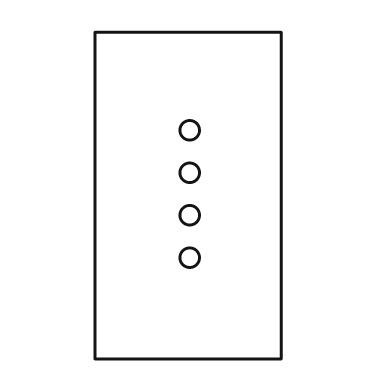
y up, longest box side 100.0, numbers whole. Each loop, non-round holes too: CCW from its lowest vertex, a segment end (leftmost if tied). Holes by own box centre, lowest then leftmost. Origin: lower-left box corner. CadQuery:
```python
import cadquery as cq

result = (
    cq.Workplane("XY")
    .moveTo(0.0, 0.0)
    .lineTo(57.0, 0.0)
    .lineTo(57.0, 100.0)
    .lineTo(0.0, 100.0)
    .close()
    .moveTo(29.0, 31.0)
    .circle(3.0)
    .moveTo(29.0, 44.0)
    .circle(3.0)
    .moveTo(29.0, 57.0)
    .circle(3.0)
    .moveTo(29.0, 70.0)
    .circle(3.0)
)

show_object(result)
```